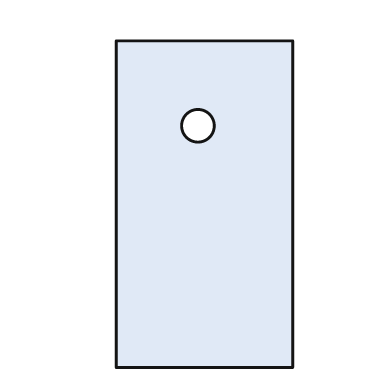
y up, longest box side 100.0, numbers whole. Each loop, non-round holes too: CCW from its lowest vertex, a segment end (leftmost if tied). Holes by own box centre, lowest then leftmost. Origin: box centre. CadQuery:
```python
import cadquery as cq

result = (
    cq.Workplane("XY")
    .moveTo(-27.0, -50.0)
    .lineTo(27.0, -50.0)
    .lineTo(27.0, 50.0)
    .lineTo(-27.0, 50.0)
    .close()
    .moveTo(-2.0, 24.0)
    .circle(5.0)
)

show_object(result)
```